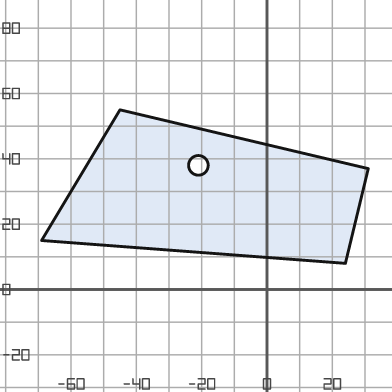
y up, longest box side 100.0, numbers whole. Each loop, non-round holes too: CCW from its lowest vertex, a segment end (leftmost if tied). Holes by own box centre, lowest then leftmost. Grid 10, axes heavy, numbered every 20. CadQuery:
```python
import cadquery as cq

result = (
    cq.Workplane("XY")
    .moveTo(24.0, 8.0)
    .lineTo(31.0, 37.0)
    .lineTo(-45.0, 55.0)
    .lineTo(-69.0, 15.0)
    .close()
    .moveTo(-21.0, 38.0)
    .circle(3.0)
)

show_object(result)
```